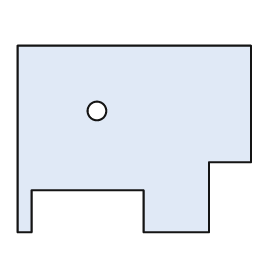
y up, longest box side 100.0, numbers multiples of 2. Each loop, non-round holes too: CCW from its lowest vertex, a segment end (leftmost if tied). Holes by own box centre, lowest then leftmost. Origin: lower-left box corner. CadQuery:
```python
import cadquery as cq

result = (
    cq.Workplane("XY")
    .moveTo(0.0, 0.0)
    .lineTo(6.0, 0.0)
    .lineTo(6.0, 18.0)
    .lineTo(54.0, 18.0)
    .lineTo(54.0, 0.0)
    .lineTo(82.0, 0.0)
    .lineTo(82.0, 30.0)
    .lineTo(100.0, 30.0)
    .lineTo(100.0, 80.0)
    .lineTo(0.0, 80.0)
    .close()
    .moveTo(34.0, 52.0)
    .circle(4.0)
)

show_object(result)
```